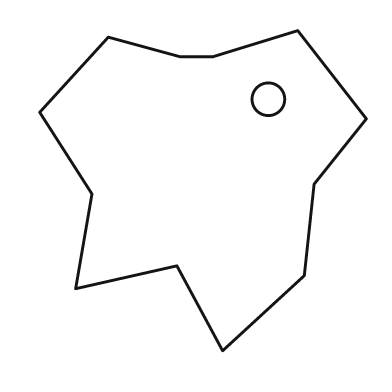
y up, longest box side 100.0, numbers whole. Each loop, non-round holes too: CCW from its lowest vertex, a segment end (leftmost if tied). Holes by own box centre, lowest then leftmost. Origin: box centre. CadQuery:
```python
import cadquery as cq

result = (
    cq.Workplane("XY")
    .moveTo(6.0, -49.0)
    .lineTo(31.0, -26.0)
    .lineTo(34.0, 2.0)
    .lineTo(50.0, 22.0)
    .lineTo(29.0, 49.0)
    .lineTo(3.0, 41.0)
    .lineTo(-7.0, 41.0)
    .lineTo(-29.0, 47.0)
    .lineTo(-50.0, 24.0)
    .lineTo(-34.0, -1.0)
    .lineTo(-39.0, -30.0)
    .lineTo(-8.0, -23.0)
    .close()
    .moveTo(20.0, 28.0)
    .circle(5.0)
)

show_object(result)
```